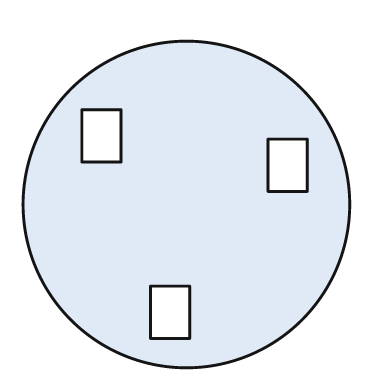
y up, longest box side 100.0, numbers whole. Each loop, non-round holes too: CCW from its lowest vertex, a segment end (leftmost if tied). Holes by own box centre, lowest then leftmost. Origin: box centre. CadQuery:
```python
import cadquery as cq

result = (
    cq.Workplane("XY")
    .moveTo(0.0, 0.0)
    .circle(50.0)
    .moveTo(-11.0, -41.0)
    .lineTo(1.0, -41.0)
    .lineTo(1.0, -25.0)
    .lineTo(-11.0, -25.0)
    .close()
    .moveTo(25.0, 4.0)
    .lineTo(37.0, 4.0)
    .lineTo(37.0, 20.0)
    .lineTo(25.0, 20.0)
    .close()
    .moveTo(-32.0, 13.0)
    .lineTo(-20.0, 13.0)
    .lineTo(-20.0, 29.0)
    .lineTo(-32.0, 29.0)
    .close()
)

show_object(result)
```